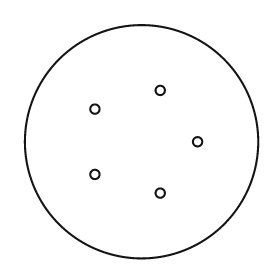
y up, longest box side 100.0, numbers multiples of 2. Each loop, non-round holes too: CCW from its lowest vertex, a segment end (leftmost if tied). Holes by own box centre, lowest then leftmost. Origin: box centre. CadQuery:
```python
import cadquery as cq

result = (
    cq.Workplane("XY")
    .moveTo(0.0, 0.0)
    .circle(50.0)
    .moveTo(8.0, -22.0)
    .circle(2.0)
    .moveTo(-20.0, -14.0)
    .circle(2.0)
    .moveTo(24.0, 0.0)
    .circle(2.0)
    .moveTo(-20.0, 14.0)
    .circle(2.0)
    .moveTo(8.0, 22.0)
    .circle(2.0)
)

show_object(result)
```